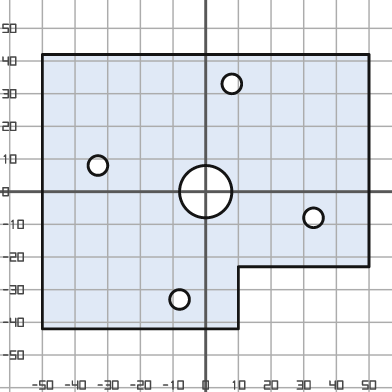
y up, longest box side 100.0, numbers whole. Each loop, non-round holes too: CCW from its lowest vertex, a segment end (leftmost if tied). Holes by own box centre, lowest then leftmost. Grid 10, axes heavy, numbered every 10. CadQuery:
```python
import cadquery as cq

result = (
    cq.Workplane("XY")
    .moveTo(-50.0, -42.0)
    .lineTo(10.0, -42.0)
    .lineTo(10.0, -23.0)
    .lineTo(50.0, -23.0)
    .lineTo(50.0, 42.0)
    .lineTo(-50.0, 42.0)
    .close()
    .moveTo(-8.0, -33.0)
    .circle(3.0)
    .moveTo(33.0, -8.0)
    .circle(3.0)
    .moveTo(0.0, 0.0)
    .circle(8.0)
    .moveTo(-33.0, 8.0)
    .circle(3.0)
    .moveTo(8.0, 33.0)
    .circle(3.0)
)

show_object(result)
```